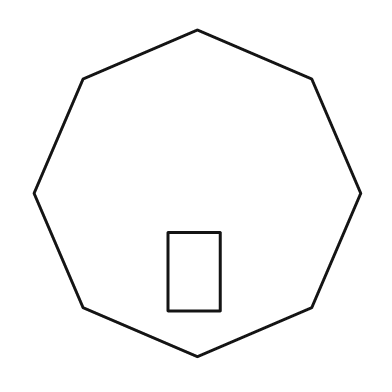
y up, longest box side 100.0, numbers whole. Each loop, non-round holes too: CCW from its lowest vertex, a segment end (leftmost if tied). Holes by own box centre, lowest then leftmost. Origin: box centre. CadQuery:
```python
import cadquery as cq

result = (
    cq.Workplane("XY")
    .moveTo(0.0, -50.0)
    .lineTo(35.0, -35.0)
    .lineTo(50.0, 0.0)
    .lineTo(35.0, 35.0)
    .lineTo(0.0, 50.0)
    .lineTo(-35.0, 35.0)
    .lineTo(-50.0, 0.0)
    .lineTo(-35.0, -35.0)
    .close()
    .moveTo(-9.0, -36.0)
    .lineTo(7.0, -36.0)
    .lineTo(7.0, -12.0)
    .lineTo(-9.0, -12.0)
    .close()
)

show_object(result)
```